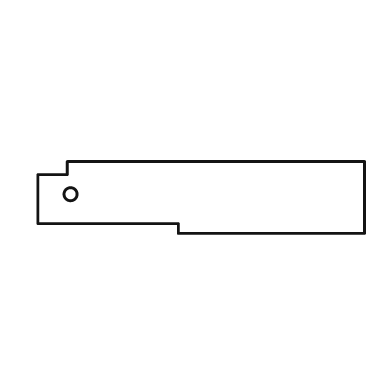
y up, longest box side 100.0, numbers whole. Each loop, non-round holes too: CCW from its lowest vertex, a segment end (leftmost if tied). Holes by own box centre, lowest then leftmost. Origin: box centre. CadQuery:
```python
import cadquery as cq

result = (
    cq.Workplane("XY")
    .moveTo(-7.0, -11.0)
    .lineTo(50.0, -11.0)
    .lineTo(50.0, 11.0)
    .lineTo(-41.0, 11.0)
    .lineTo(-41.0, 7.0)
    .lineTo(-50.0, 7.0)
    .lineTo(-50.0, -8.0)
    .lineTo(-7.0, -8.0)
    .close()
    .moveTo(-40.0, 1.0)
    .circle(2.0)
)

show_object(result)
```